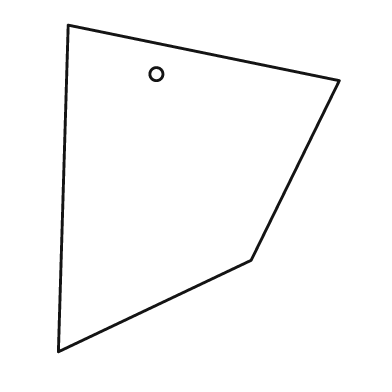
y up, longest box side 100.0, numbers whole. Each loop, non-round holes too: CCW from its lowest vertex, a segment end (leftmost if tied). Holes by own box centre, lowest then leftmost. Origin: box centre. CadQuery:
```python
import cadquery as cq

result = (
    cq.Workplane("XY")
    .moveTo(-43.0, -50.0)
    .lineTo(16.0, -22.0)
    .lineTo(43.0, 33.0)
    .lineTo(-40.0, 50.0)
    .close()
    .moveTo(-13.0, 35.0)
    .circle(2.0)
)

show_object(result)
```